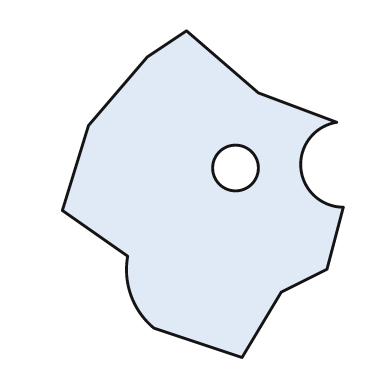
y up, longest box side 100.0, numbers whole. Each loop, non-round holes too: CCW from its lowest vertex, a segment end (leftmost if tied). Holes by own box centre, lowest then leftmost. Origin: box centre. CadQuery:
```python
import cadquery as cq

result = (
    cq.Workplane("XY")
    .moveTo(12.0, -50.0)
    .lineTo(24.0, -30.0)
    .lineTo(38.0, -23.0)
    .lineTo(43.0, -4.0)
    .threePointArc((30.0, 8.0), (41.0, 22.0))
    .lineTo(17.0, 31.0)
    .lineTo(-5.0, 50.0)
    .lineTo(-17.0, 42.0)
    .lineTo(-35.0, 21.0)
    .lineTo(-43.0, -5.0)
    .lineTo(-23.0, -19.0)
    .threePointArc((-22.0, -31.0), (-15.0, -41.0))
    .close()
    .moveTo(10.0, 8.0)
    .circle(7.0)
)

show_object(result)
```